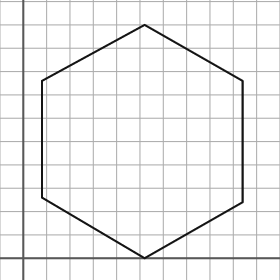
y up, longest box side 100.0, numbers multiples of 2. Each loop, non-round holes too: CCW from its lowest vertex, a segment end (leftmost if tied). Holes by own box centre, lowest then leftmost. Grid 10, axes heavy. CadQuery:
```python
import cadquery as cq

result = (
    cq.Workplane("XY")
    .moveTo(52.0, 0.0)
    .lineTo(94.0, 24.0)
    .lineTo(94.0, 76.0)
    .lineTo(52.0, 100.0)
    .lineTo(8.0, 76.0)
    .lineTo(8.0, 26.0)
    .close()
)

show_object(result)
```